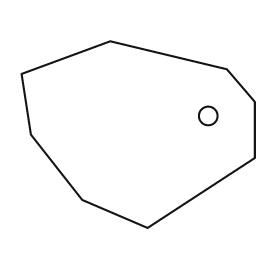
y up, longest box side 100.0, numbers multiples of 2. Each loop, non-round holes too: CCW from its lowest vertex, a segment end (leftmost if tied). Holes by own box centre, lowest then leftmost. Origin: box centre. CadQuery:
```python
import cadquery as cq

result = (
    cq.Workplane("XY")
    .moveTo(4.0, -40.0)
    .lineTo(50.0, -10.0)
    .lineTo(50.0, 14.0)
    .lineTo(38.0, 28.0)
    .lineTo(-12.0, 40.0)
    .lineTo(-50.0, 26.0)
    .lineTo(-46.0, 0.0)
    .lineTo(-24.0, -28.0)
    .close()
    .moveTo(30.0, 8.0)
    .circle(4.0)
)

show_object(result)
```